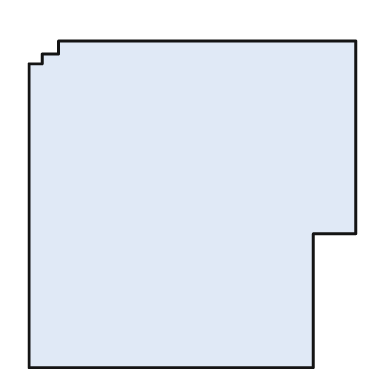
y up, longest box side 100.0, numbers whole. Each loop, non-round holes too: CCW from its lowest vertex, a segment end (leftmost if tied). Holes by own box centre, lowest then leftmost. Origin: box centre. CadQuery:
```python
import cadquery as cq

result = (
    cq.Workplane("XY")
    .moveTo(-50.0, -50.0)
    .lineTo(37.0, -50.0)
    .lineTo(37.0, -9.0)
    .lineTo(50.0, -9.0)
    .lineTo(50.0, 50.0)
    .lineTo(-41.0, 50.0)
    .lineTo(-41.0, 46.0)
    .lineTo(-46.0, 46.0)
    .lineTo(-46.0, 43.0)
    .lineTo(-50.0, 43.0)
    .close()
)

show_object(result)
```